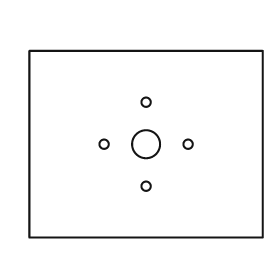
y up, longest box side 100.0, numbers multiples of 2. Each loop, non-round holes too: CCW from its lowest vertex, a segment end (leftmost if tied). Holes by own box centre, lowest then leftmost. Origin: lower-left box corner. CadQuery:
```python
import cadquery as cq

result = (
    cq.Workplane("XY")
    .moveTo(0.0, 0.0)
    .lineTo(100.0, 0.0)
    .lineTo(100.0, 80.0)
    .lineTo(0.0, 80.0)
    .close()
    .moveTo(50.0, 22.0)
    .circle(2.0)
    .moveTo(32.0, 40.0)
    .circle(2.0)
    .moveTo(50.0, 40.0)
    .circle(6.0)
    .moveTo(68.0, 40.0)
    .circle(2.0)
    .moveTo(50.0, 58.0)
    .circle(2.0)
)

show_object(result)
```